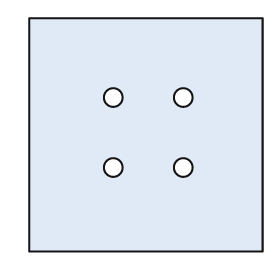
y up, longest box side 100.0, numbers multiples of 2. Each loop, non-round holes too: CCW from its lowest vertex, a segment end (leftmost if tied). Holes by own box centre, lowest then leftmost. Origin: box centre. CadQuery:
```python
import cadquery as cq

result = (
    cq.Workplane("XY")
    .moveTo(-50.0, -50.0)
    .lineTo(50.0, -50.0)
    .lineTo(50.0, 50.0)
    .lineTo(-50.0, 50.0)
    .close()
    .moveTo(-14.0, -14.0)
    .circle(4.0)
    .moveTo(16.0, -14.0)
    .circle(4.0)
    .moveTo(-14.0, 16.0)
    .circle(4.0)
    .moveTo(16.0, 16.0)
    .circle(4.0)
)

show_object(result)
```